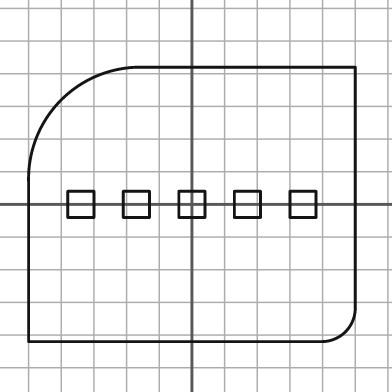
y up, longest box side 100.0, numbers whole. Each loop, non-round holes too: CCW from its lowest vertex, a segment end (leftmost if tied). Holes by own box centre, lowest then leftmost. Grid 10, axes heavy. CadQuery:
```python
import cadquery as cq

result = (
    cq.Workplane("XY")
    .moveTo(-50.0, -42.0)
    .lineTo(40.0, -42.0)
    .threePointArc((47.0, -39.0), (50.0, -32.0))
    .lineTo(50.0, 42.0)
    .lineTo(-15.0, 42.0)
    .threePointArc((-40.0, 32.0), (-50.0, 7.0))
    .close()
    .moveTo(-38.0, -4.0)
    .lineTo(-30.0, -4.0)
    .lineTo(-30.0, 4.0)
    .lineTo(-38.0, 4.0)
    .close()
    .moveTo(-21.0, -4.0)
    .lineTo(-13.0, -4.0)
    .lineTo(-13.0, 4.0)
    .lineTo(-21.0, 4.0)
    .close()
    .moveTo(-4.0, -4.0)
    .lineTo(4.0, -4.0)
    .lineTo(4.0, 4.0)
    .lineTo(-4.0, 4.0)
    .close()
    .moveTo(13.0, -4.0)
    .lineTo(21.0, -4.0)
    .lineTo(21.0, 4.0)
    .lineTo(13.0, 4.0)
    .close()
    .moveTo(30.0, -4.0)
    .lineTo(38.0, -4.0)
    .lineTo(38.0, 4.0)
    .lineTo(30.0, 4.0)
    .close()
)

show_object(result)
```